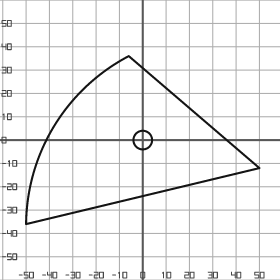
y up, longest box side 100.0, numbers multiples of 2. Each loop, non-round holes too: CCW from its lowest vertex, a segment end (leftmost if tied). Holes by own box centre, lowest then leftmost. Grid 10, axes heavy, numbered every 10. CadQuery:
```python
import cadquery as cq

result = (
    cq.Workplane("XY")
    .moveTo(-50.0, -36.0)
    .lineTo(50.0, -12.0)
    .lineTo(-6.0, 36.0)
    .threePointArc((-38.0, 6.0), (-50.0, -36.0))
    .close()
    .moveTo(0.0, 0.0)
    .circle(4.0)
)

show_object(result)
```